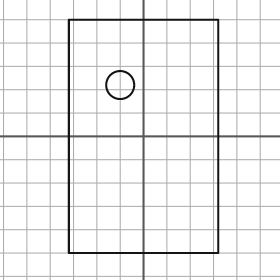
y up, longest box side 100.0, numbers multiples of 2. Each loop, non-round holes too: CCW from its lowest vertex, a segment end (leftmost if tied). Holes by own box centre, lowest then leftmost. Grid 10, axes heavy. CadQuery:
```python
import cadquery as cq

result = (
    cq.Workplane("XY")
    .moveTo(-32.0, -50.0)
    .lineTo(32.0, -50.0)
    .lineTo(32.0, 50.0)
    .lineTo(-32.0, 50.0)
    .close()
    .moveTo(-10.0, 22.0)
    .circle(6.0)
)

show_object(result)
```